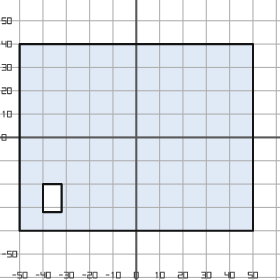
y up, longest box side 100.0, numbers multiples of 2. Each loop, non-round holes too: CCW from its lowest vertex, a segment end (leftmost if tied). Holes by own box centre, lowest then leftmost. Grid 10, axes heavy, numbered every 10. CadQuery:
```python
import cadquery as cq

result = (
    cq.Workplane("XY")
    .moveTo(-50.0, -40.0)
    .lineTo(50.0, -40.0)
    .lineTo(50.0, 40.0)
    .lineTo(-50.0, 40.0)
    .close()
    .moveTo(-40.0, -32.0)
    .lineTo(-32.0, -32.0)
    .lineTo(-32.0, -20.0)
    .lineTo(-40.0, -20.0)
    .close()
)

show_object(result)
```